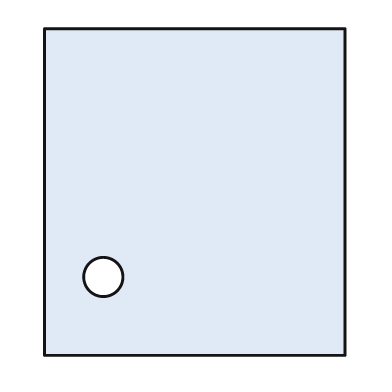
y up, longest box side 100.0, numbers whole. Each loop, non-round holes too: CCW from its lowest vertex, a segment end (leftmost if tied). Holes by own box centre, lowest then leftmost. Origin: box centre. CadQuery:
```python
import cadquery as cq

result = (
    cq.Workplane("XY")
    .moveTo(-46.0, -50.0)
    .lineTo(46.0, -50.0)
    .lineTo(46.0, 50.0)
    .lineTo(-46.0, 50.0)
    .close()
    .moveTo(-28.0, -26.0)
    .circle(6.0)
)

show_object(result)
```